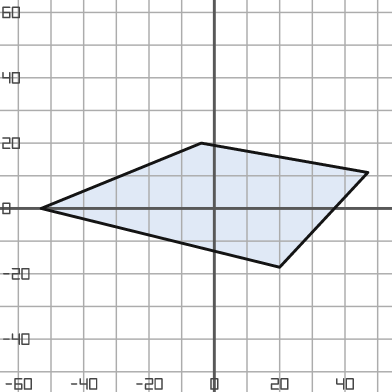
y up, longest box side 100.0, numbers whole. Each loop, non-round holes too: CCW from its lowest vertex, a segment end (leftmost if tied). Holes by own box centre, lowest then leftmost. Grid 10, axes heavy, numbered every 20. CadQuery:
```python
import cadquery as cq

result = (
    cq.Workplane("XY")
    .moveTo(20.0, -18.0)
    .lineTo(47.0, 11.0)
    .lineTo(-4.0, 20.0)
    .lineTo(-53.0, 0.0)
    .close()
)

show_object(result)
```